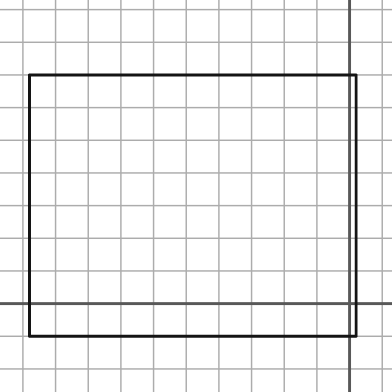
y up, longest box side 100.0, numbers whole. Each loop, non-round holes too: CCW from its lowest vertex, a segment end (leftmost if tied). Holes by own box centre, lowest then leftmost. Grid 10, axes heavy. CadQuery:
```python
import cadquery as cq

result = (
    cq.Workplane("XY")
    .moveTo(-98.0, -10.0)
    .lineTo(2.0, -10.0)
    .lineTo(2.0, 70.0)
    .lineTo(-98.0, 70.0)
    .close()
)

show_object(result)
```